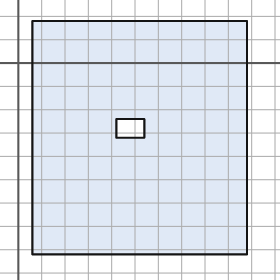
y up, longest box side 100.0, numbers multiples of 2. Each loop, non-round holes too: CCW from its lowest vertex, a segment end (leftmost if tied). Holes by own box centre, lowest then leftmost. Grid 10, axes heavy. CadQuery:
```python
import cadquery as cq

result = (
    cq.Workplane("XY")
    .moveTo(6.0, -82.0)
    .lineTo(98.0, -82.0)
    .lineTo(98.0, 18.0)
    .lineTo(6.0, 18.0)
    .close()
    .moveTo(42.0, -32.0)
    .lineTo(54.0, -32.0)
    .lineTo(54.0, -24.0)
    .lineTo(42.0, -24.0)
    .close()
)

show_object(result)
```